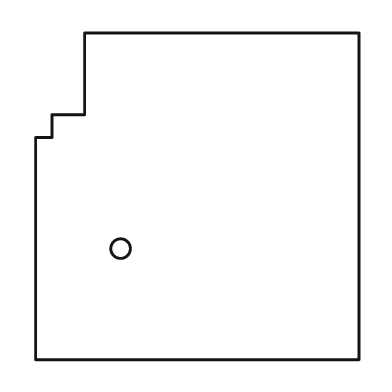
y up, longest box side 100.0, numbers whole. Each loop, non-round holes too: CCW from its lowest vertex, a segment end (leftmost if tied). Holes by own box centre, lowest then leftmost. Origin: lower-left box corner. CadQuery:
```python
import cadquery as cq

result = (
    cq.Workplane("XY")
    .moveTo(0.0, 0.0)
    .lineTo(99.0, 0.0)
    .lineTo(99.0, 100.0)
    .lineTo(15.0, 100.0)
    .lineTo(15.0, 75.0)
    .lineTo(5.0, 75.0)
    .lineTo(5.0, 68.0)
    .lineTo(0.0, 68.0)
    .close()
    .moveTo(26.0, 34.0)
    .circle(3.0)
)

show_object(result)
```